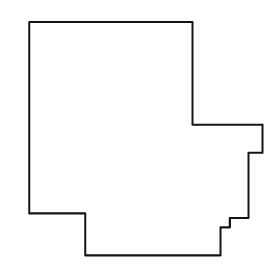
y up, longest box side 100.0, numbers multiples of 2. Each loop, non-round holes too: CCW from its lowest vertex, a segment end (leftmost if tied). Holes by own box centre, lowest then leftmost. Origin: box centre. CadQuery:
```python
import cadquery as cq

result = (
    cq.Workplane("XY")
    .moveTo(-26.0, -50.0)
    .lineTo(32.0, -50.0)
    .lineTo(32.0, -38.0)
    .lineTo(36.0, -38.0)
    .lineTo(36.0, -34.0)
    .lineTo(44.0, -34.0)
    .lineTo(44.0, -6.0)
    .lineTo(50.0, -6.0)
    .lineTo(50.0, 6.0)
    .lineTo(20.0, 6.0)
    .lineTo(20.0, 50.0)
    .lineTo(-50.0, 50.0)
    .lineTo(-50.0, -32.0)
    .lineTo(-26.0, -32.0)
    .close()
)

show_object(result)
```